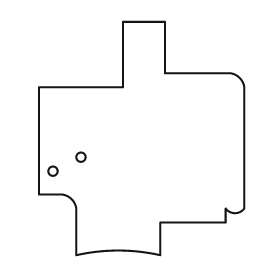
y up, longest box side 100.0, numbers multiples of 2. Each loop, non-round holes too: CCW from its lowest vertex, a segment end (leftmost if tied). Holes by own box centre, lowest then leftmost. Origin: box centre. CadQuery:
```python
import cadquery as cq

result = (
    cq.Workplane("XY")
    .moveTo(-28.0, -50.0)
    .threePointArc((-10.0, -48.0), (8.0, -50.0))
    .lineTo(8.0, -36.0)
    .lineTo(36.0, -36.0)
    .lineTo(36.0, -30.0)
    .threePointArc((40.0, -32.0), (44.0, -30.0))
    .lineTo(44.0, 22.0)
    .threePointArc((42.0, 26.0), (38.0, 28.0))
    .lineTo(10.0, 28.0)
    .lineTo(10.0, 50.0)
    .lineTo(-8.0, 50.0)
    .lineTo(-8.0, 22.0)
    .lineTo(-44.0, 22.0)
    .lineTo(-44.0, -24.0)
    .lineTo(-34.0, -24.0)
    .threePointArc((-30.0, -26.0), (-28.0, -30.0))
    .close()
    .moveTo(-38.0, -14.0)
    .circle(2.0)
    .moveTo(-26.0, -8.0)
    .circle(2.0)
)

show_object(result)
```